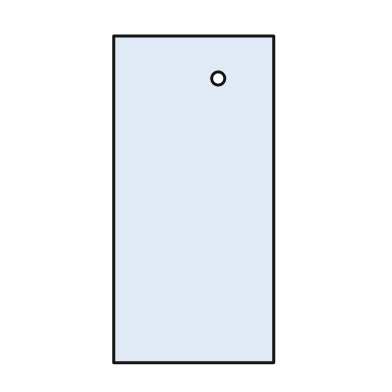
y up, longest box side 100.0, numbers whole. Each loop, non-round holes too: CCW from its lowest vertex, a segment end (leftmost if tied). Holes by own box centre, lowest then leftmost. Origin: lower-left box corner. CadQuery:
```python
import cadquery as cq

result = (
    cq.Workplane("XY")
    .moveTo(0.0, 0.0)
    .lineTo(49.0, 0.0)
    .lineTo(49.0, 100.0)
    .lineTo(0.0, 100.0)
    .close()
    .moveTo(32.0, 87.0)
    .circle(2.0)
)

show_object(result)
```